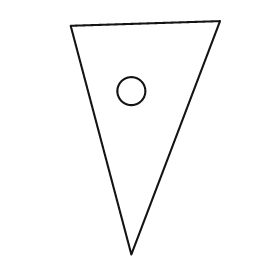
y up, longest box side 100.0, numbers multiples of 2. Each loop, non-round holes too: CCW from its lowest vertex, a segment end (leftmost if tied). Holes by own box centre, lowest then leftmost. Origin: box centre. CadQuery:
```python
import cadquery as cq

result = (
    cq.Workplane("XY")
    .moveTo(-6.0, -50.0)
    .lineTo(32.0, 50.0)
    .lineTo(-32.0, 48.0)
    .close()
    .moveTo(-6.0, 20.0)
    .circle(6.0)
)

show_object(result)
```